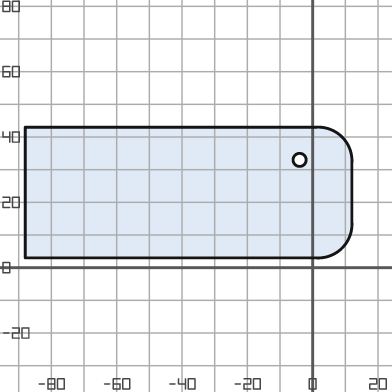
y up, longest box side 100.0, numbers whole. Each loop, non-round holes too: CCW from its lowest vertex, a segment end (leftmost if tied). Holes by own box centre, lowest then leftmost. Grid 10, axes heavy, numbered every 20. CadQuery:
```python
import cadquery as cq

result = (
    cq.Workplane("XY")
    .moveTo(-88.0, 3.0)
    .lineTo(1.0, 3.0)
    .threePointArc((9.0, 6.0), (12.0, 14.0))
    .lineTo(12.0, 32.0)
    .threePointArc((9.0, 40.0), (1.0, 43.0))
    .lineTo(-88.0, 43.0)
    .close()
    .moveTo(-4.0, 33.0)
    .circle(2.0)
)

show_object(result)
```